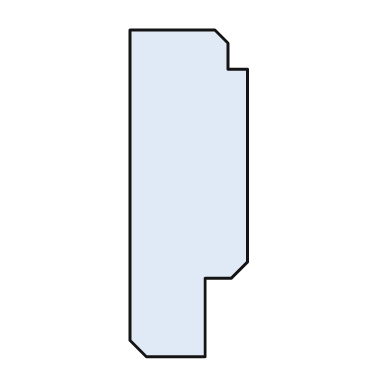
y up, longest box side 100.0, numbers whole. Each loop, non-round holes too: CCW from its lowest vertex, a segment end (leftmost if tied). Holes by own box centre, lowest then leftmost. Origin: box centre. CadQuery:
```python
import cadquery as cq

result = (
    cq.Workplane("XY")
    .moveTo(-13.0, -50.0)
    .lineTo(5.0, -50.0)
    .lineTo(5.0, -26.0)
    .lineTo(13.0, -26.0)
    .lineTo(18.0, -21.0)
    .lineTo(18.0, 38.0)
    .lineTo(12.0, 38.0)
    .lineTo(12.0, 46.0)
    .lineTo(8.0, 50.0)
    .lineTo(-18.0, 50.0)
    .lineTo(-18.0, -45.0)
    .close()
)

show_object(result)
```